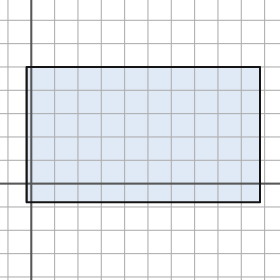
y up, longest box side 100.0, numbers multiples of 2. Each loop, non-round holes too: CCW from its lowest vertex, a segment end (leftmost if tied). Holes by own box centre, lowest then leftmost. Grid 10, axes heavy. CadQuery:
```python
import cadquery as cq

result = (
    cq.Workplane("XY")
    .moveTo(-2.0, -8.0)
    .lineTo(98.0, -8.0)
    .lineTo(98.0, 50.0)
    .lineTo(-2.0, 50.0)
    .close()
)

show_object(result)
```